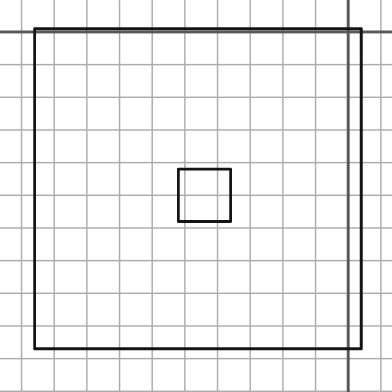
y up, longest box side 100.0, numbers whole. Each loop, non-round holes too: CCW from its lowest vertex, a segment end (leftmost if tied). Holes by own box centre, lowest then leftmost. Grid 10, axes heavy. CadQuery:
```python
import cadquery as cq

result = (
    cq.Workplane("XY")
    .moveTo(-96.0, -97.0)
    .lineTo(4.0, -97.0)
    .lineTo(4.0, 1.0)
    .lineTo(-96.0, 1.0)
    .close()
    .moveTo(-52.0, -58.0)
    .lineTo(-36.0, -58.0)
    .lineTo(-36.0, -42.0)
    .lineTo(-52.0, -42.0)
    .close()
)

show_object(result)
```